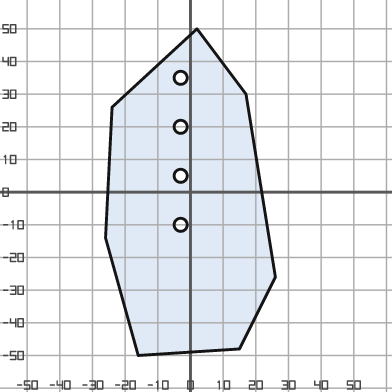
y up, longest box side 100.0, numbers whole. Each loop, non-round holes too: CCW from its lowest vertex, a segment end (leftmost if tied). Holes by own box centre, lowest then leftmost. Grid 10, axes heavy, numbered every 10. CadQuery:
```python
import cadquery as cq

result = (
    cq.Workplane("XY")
    .moveTo(-16.0, -50.0)
    .lineTo(15.0, -48.0)
    .lineTo(26.0, -26.0)
    .lineTo(17.0, 30.0)
    .lineTo(2.0, 50.0)
    .lineTo(-24.0, 26.0)
    .lineTo(-26.0, -14.0)
    .close()
    .moveTo(-3.0, -10.0)
    .circle(2.0)
    .moveTo(-3.0, 5.0)
    .circle(2.0)
    .moveTo(-3.0, 20.0)
    .circle(2.0)
    .moveTo(-3.0, 35.0)
    .circle(2.0)
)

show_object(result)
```